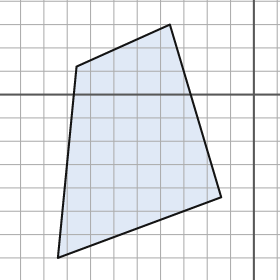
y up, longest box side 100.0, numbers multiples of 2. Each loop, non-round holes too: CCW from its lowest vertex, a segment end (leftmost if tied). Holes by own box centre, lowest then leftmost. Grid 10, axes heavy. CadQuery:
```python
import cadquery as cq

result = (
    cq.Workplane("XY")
    .moveTo(-84.0, -70.0)
    .lineTo(-14.0, -44.0)
    .lineTo(-36.0, 30.0)
    .lineTo(-76.0, 12.0)
    .close()
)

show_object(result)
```